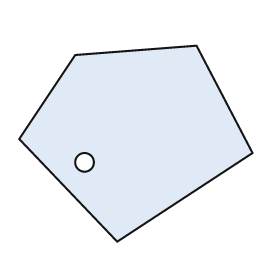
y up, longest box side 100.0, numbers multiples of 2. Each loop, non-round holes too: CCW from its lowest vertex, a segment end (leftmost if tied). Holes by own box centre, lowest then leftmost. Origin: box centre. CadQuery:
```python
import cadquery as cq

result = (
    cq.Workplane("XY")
    .moveTo(-8.0, -42.0)
    .lineTo(50.0, -4.0)
    .lineTo(26.0, 42.0)
    .lineTo(-26.0, 38.0)
    .lineTo(-50.0, 2.0)
    .close()
    .moveTo(-22.0, -8.0)
    .circle(4.0)
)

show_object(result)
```